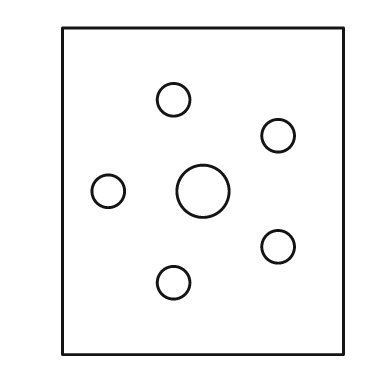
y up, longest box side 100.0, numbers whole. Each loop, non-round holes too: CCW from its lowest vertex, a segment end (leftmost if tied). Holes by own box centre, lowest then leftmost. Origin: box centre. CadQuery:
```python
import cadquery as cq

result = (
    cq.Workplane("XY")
    .moveTo(-43.0, -50.0)
    .lineTo(43.0, -50.0)
    .lineTo(43.0, 50.0)
    .lineTo(-43.0, 50.0)
    .close()
    .moveTo(-9.0, -28.0)
    .circle(5.0)
    .moveTo(23.0, -17.0)
    .circle(5.0)
    .moveTo(-29.0, 0.0)
    .circle(5.0)
    .moveTo(0.0, 0.0)
    .circle(8.0)
    .moveTo(23.0, 17.0)
    .circle(5.0)
    .moveTo(-9.0, 28.0)
    .circle(5.0)
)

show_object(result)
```